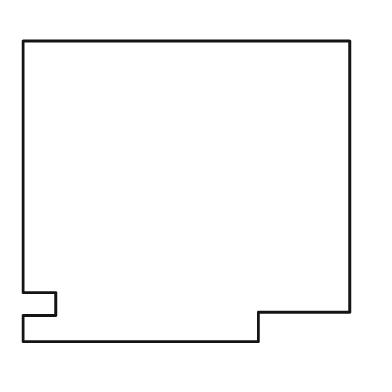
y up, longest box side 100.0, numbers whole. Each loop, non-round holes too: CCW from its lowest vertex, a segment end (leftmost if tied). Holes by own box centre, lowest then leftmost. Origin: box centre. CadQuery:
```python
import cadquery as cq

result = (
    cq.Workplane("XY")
    .moveTo(-50.0, -46.0)
    .lineTo(22.0, -46.0)
    .lineTo(22.0, -37.0)
    .lineTo(50.0, -37.0)
    .lineTo(50.0, 46.0)
    .lineTo(-50.0, 46.0)
    .lineTo(-50.0, -31.0)
    .lineTo(-40.0, -31.0)
    .lineTo(-40.0, -38.0)
    .lineTo(-50.0, -38.0)
    .close()
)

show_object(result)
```